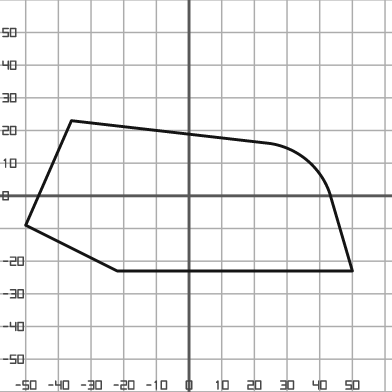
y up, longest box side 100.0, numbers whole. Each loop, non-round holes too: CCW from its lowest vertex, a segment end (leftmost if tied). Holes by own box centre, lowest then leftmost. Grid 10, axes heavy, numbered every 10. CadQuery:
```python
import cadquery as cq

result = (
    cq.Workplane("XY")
    .moveTo(-22.0, -23.0)
    .lineTo(50.0, -23.0)
    .lineTo(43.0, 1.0)
    .threePointArc((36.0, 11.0), (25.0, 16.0))
    .lineTo(-36.0, 23.0)
    .lineTo(-50.0, -9.0)
    .close()
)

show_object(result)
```